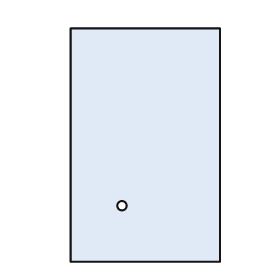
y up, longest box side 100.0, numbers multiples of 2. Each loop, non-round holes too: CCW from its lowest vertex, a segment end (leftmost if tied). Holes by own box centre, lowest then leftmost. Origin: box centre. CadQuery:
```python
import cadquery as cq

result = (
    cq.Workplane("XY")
    .moveTo(-32.0, -50.0)
    .lineTo(32.0, -50.0)
    .lineTo(32.0, 50.0)
    .lineTo(-32.0, 50.0)
    .close()
    .moveTo(-10.0, -26.0)
    .circle(2.0)
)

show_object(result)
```